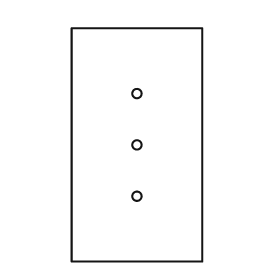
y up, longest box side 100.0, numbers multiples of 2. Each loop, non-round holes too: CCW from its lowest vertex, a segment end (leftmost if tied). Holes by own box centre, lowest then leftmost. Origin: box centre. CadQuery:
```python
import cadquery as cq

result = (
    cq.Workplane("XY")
    .moveTo(-28.0, -50.0)
    .lineTo(28.0, -50.0)
    .lineTo(28.0, 50.0)
    .lineTo(-28.0, 50.0)
    .close()
    .moveTo(0.0, -22.0)
    .circle(2.0)
    .moveTo(0.0, 0.0)
    .circle(2.0)
    .moveTo(0.0, 22.0)
    .circle(2.0)
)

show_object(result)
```